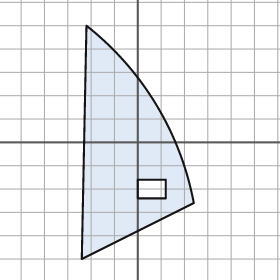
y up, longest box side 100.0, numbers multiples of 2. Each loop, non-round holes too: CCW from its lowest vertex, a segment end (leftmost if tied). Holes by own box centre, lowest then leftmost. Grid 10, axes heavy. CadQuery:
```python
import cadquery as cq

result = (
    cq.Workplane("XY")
    .moveTo(-24.0, -50.0)
    .lineTo(24.0, -26.0)
    .threePointArc((8.0, 16.0), (-22.0, 50.0))
    .close()
    .moveTo(0.0, -24.0)
    .lineTo(12.0, -24.0)
    .lineTo(12.0, -16.0)
    .lineTo(0.0, -16.0)
    .close()
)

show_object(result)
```